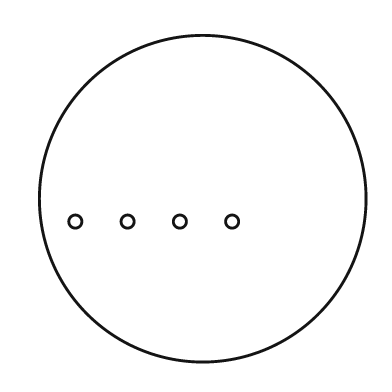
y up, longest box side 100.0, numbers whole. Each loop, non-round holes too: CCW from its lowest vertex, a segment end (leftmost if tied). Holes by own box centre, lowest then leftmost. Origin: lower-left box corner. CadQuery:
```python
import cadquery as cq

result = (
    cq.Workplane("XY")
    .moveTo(50.0, 50.0)
    .circle(50.0)
    .moveTo(11.0, 43.0)
    .circle(2.0)
    .moveTo(27.0, 43.0)
    .circle(2.0)
    .moveTo(43.0, 43.0)
    .circle(2.0)
    .moveTo(59.0, 43.0)
    .circle(2.0)
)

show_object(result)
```